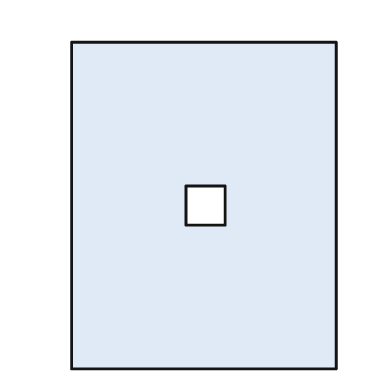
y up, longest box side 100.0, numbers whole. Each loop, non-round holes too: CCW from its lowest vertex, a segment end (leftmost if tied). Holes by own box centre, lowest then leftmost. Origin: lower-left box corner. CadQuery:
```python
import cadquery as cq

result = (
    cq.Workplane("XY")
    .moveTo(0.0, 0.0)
    .lineTo(81.0, 0.0)
    .lineTo(81.0, 100.0)
    .lineTo(0.0, 100.0)
    .close()
    .moveTo(35.0, 44.0)
    .lineTo(47.0, 44.0)
    .lineTo(47.0, 56.0)
    .lineTo(35.0, 56.0)
    .close()
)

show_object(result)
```